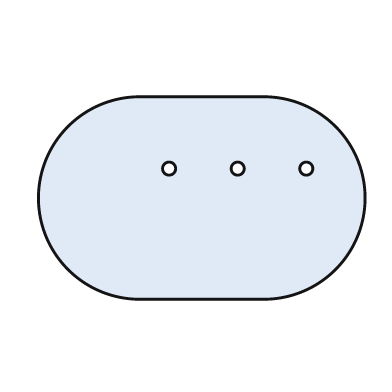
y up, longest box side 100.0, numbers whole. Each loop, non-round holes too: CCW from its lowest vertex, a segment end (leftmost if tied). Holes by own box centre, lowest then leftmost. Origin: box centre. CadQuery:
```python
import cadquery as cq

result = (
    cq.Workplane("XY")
    .moveTo(-19.0, -31.0)
    .lineTo(19.0, -31.0)
    .threePointArc((50.0, 0.0), (19.0, 31.0))
    .lineTo(-19.0, 31.0)
    .threePointArc((-50.0, 0.0), (-19.0, -31.0))
    .close()
    .moveTo(-10.0, 9.0)
    .circle(2.0)
    .moveTo(11.0, 9.0)
    .circle(2.0)
    .moveTo(32.0, 9.0)
    .circle(2.0)
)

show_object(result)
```